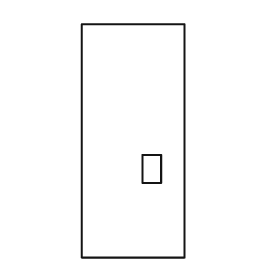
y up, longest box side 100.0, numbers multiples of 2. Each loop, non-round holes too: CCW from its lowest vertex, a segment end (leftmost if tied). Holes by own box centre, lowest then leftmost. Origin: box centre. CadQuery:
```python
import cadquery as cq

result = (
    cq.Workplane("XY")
    .moveTo(-22.0, -50.0)
    .lineTo(22.0, -50.0)
    .lineTo(22.0, 50.0)
    .lineTo(-22.0, 50.0)
    .close()
    .moveTo(4.0, -18.0)
    .lineTo(12.0, -18.0)
    .lineTo(12.0, -6.0)
    .lineTo(4.0, -6.0)
    .close()
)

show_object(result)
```